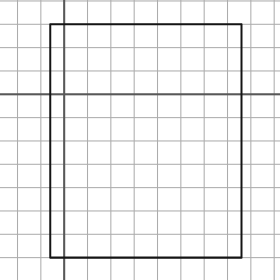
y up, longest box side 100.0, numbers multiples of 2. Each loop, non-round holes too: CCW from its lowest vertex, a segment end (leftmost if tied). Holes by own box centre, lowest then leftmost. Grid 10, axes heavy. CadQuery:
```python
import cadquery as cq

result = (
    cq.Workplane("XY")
    .moveTo(-6.0, -70.0)
    .lineTo(76.0, -70.0)
    .lineTo(76.0, 30.0)
    .lineTo(-6.0, 30.0)
    .close()
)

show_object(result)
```